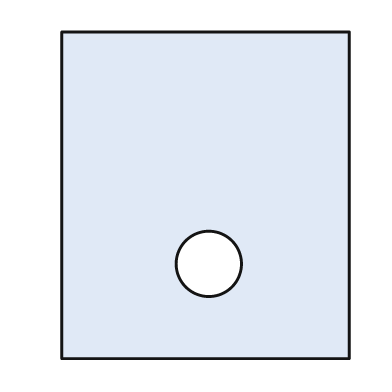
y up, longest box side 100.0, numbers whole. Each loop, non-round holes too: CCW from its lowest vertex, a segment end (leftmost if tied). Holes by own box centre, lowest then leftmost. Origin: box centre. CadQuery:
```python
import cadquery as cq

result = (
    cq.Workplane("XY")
    .moveTo(-44.0, -50.0)
    .lineTo(44.0, -50.0)
    .lineTo(44.0, 50.0)
    .lineTo(-44.0, 50.0)
    .close()
    .moveTo(1.0, -21.0)
    .circle(10.0)
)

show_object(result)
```